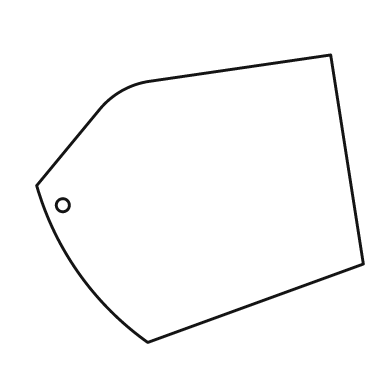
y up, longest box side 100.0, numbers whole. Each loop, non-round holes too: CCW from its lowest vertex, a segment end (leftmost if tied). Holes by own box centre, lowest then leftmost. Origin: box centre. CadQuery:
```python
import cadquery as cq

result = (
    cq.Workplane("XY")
    .moveTo(-16.0, -44.0)
    .lineTo(50.0, -20.0)
    .lineTo(40.0, 44.0)
    .lineTo(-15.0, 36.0)
    .threePointArc((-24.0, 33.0), (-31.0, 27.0))
    .lineTo(-50.0, 4.0)
    .threePointArc((-37.0, -23.0), (-16.0, -44.0))
    .close()
    .moveTo(-42.0, -2.0)
    .circle(2.0)
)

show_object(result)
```